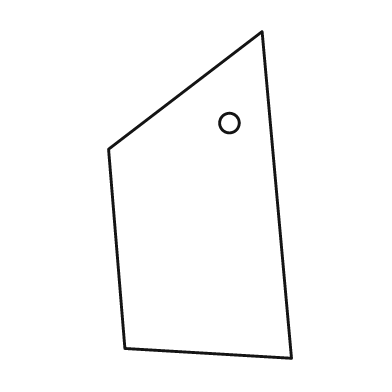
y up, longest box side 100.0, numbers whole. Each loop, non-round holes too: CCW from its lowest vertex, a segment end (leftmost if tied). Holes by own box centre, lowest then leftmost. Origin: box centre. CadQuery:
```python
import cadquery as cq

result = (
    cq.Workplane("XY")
    .moveTo(28.0, -50.0)
    .lineTo(19.0, 50.0)
    .lineTo(-28.0, 14.0)
    .lineTo(-23.0, -47.0)
    .close()
    .moveTo(9.0, 22.0)
    .circle(3.0)
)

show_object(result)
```